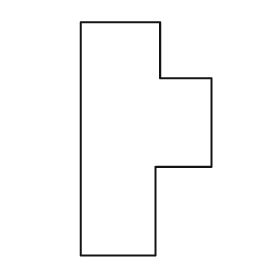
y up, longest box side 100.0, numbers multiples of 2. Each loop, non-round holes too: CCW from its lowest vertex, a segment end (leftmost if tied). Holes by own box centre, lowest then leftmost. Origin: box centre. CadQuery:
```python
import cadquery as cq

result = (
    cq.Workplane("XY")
    .moveTo(-28.0, -50.0)
    .lineTo(4.0, -50.0)
    .lineTo(4.0, -12.0)
    .lineTo(28.0, -12.0)
    .lineTo(28.0, 26.0)
    .lineTo(6.0, 26.0)
    .lineTo(6.0, 50.0)
    .lineTo(-28.0, 50.0)
    .close()
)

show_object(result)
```